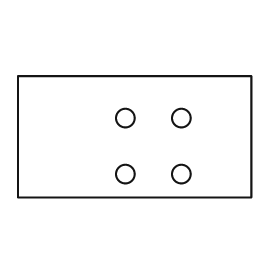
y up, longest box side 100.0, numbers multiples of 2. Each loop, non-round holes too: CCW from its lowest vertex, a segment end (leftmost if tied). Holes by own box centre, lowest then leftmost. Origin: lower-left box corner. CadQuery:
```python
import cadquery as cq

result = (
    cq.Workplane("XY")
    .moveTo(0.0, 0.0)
    .lineTo(100.0, 0.0)
    .lineTo(100.0, 52.0)
    .lineTo(0.0, 52.0)
    .close()
    .moveTo(46.0, 10.0)
    .circle(4.0)
    .moveTo(70.0, 10.0)
    .circle(4.0)
    .moveTo(46.0, 34.0)
    .circle(4.0)
    .moveTo(70.0, 34.0)
    .circle(4.0)
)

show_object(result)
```